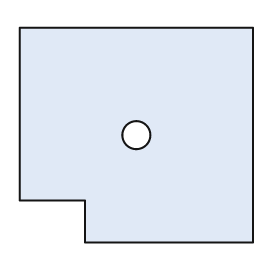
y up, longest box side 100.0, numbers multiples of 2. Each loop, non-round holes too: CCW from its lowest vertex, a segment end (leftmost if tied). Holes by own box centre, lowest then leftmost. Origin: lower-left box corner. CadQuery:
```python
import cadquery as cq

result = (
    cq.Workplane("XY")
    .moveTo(28.0, 0.0)
    .lineTo(100.0, 0.0)
    .lineTo(100.0, 92.0)
    .lineTo(0.0, 92.0)
    .lineTo(0.0, 18.0)
    .lineTo(28.0, 18.0)
    .close()
    .moveTo(50.0, 46.0)
    .circle(6.0)
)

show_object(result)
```